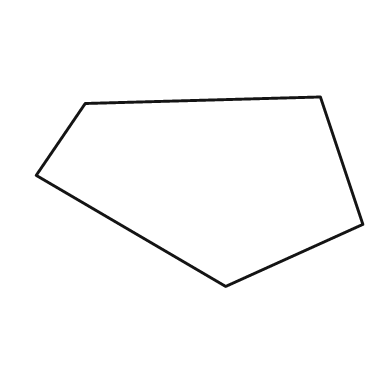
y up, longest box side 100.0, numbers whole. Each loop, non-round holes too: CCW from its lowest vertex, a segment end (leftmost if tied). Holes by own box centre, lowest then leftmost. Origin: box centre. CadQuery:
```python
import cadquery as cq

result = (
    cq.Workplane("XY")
    .moveTo(8.0, -29.0)
    .lineTo(50.0, -10.0)
    .lineTo(37.0, 29.0)
    .lineTo(-35.0, 27.0)
    .lineTo(-50.0, 5.0)
    .close()
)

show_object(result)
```